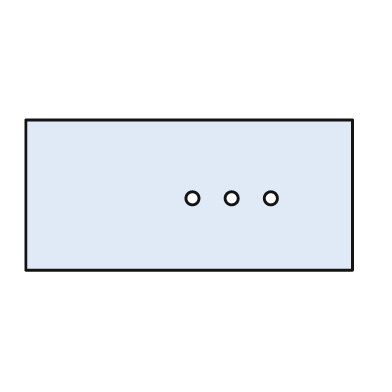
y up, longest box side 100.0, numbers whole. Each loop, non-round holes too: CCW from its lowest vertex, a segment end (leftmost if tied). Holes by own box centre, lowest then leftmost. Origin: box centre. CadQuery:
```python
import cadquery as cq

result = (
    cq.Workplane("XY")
    .moveTo(-50.0, -23.0)
    .lineTo(50.0, -23.0)
    .lineTo(50.0, 23.0)
    .lineTo(-50.0, 23.0)
    .close()
    .moveTo(1.0, -1.0)
    .circle(2.0)
    .moveTo(13.0, -1.0)
    .circle(2.0)
    .moveTo(25.0, -1.0)
    .circle(2.0)
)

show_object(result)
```